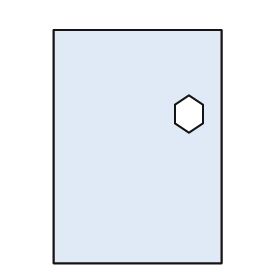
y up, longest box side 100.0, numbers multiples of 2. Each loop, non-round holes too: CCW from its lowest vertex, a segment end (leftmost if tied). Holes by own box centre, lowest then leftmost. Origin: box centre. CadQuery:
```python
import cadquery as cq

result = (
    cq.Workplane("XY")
    .moveTo(-36.0, -50.0)
    .lineTo(36.0, -50.0)
    .lineTo(36.0, 50.0)
    .lineTo(-36.0, 50.0)
    .close()
    .moveTo(22.0, 6.0)
    .lineTo(28.0, 10.0)
    .lineTo(28.0, 18.0)
    .lineTo(22.0, 22.0)
    .lineTo(16.0, 18.0)
    .lineTo(16.0, 10.0)
    .close()
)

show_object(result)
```